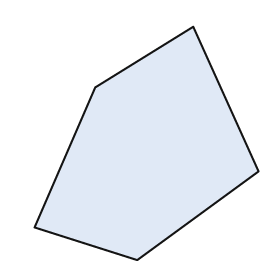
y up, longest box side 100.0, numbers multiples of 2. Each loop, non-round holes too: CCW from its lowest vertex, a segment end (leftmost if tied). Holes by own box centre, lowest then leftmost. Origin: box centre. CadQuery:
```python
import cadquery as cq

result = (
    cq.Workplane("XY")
    .moveTo(-4.0, -50.0)
    .lineTo(48.0, -12.0)
    .lineTo(20.0, 50.0)
    .lineTo(-22.0, 24.0)
    .lineTo(-48.0, -36.0)
    .close()
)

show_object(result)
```